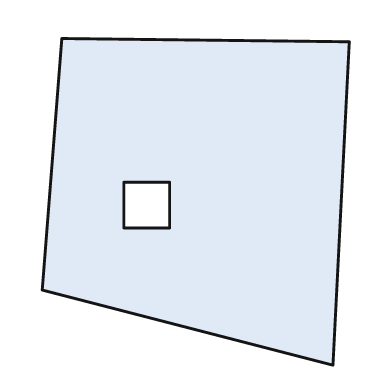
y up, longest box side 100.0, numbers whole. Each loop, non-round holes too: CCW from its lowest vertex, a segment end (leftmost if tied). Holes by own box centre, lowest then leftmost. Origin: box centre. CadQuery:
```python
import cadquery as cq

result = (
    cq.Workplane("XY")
    .moveTo(42.0, -50.0)
    .lineTo(47.0, 49.0)
    .lineTo(-41.0, 50.0)
    .lineTo(-47.0, -27.0)
    .close()
    .moveTo(-22.0, -8.0)
    .lineTo(-8.0, -8.0)
    .lineTo(-8.0, 6.0)
    .lineTo(-22.0, 6.0)
    .close()
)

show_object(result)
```